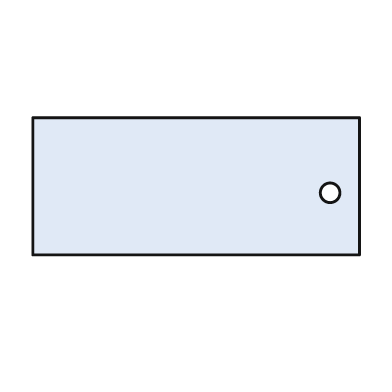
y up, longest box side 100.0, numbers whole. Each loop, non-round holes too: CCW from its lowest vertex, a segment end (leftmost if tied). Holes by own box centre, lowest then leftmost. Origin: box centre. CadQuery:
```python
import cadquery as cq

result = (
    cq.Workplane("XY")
    .moveTo(-50.0, -21.0)
    .lineTo(50.0, -21.0)
    .lineTo(50.0, 21.0)
    .lineTo(-50.0, 21.0)
    .close()
    .moveTo(41.0, -2.0)
    .circle(3.0)
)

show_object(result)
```